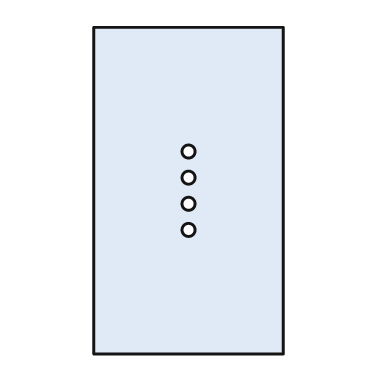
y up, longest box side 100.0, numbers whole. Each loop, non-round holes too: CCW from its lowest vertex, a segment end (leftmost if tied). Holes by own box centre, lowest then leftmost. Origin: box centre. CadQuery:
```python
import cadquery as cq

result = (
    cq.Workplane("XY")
    .moveTo(-29.0, -50.0)
    .lineTo(29.0, -50.0)
    .lineTo(29.0, 50.0)
    .lineTo(-29.0, 50.0)
    .close()
    .moveTo(0.0, -12.0)
    .circle(2.0)
    .moveTo(0.0, -4.0)
    .circle(2.0)
    .moveTo(0.0, 4.0)
    .circle(2.0)
    .moveTo(0.0, 12.0)
    .circle(2.0)
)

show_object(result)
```